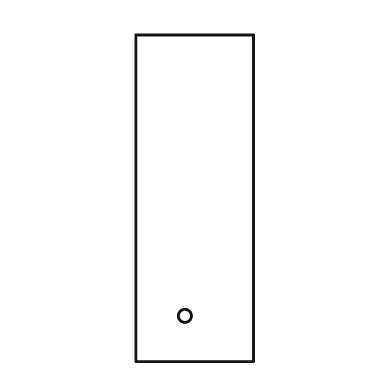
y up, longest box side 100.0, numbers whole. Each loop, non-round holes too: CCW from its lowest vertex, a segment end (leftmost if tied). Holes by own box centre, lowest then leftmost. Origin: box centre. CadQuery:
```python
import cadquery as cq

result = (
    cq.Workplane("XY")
    .moveTo(-18.0, -50.0)
    .lineTo(18.0, -50.0)
    .lineTo(18.0, 50.0)
    .lineTo(-18.0, 50.0)
    .close()
    .moveTo(-3.0, -36.0)
    .circle(2.0)
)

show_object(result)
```